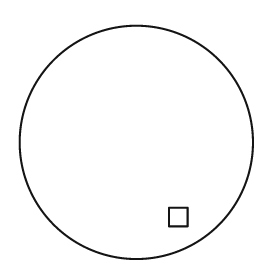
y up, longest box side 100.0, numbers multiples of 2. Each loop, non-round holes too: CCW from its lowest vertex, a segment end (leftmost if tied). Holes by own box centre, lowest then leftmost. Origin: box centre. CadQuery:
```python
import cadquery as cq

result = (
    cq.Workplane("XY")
    .moveTo(0.0, 0.0)
    .circle(50.0)
    .moveTo(14.0, -36.0)
    .lineTo(22.0, -36.0)
    .lineTo(22.0, -28.0)
    .lineTo(14.0, -28.0)
    .close()
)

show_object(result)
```